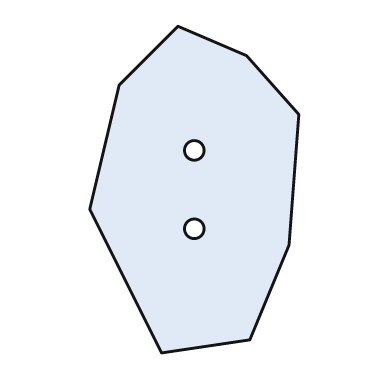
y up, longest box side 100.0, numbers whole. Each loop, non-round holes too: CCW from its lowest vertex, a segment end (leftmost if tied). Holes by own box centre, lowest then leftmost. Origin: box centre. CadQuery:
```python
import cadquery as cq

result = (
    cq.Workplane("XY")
    .moveTo(-10.0, -50.0)
    .lineTo(17.0, -46.0)
    .lineTo(29.0, -17.0)
    .lineTo(32.0, 23.0)
    .lineTo(16.0, 41.0)
    .lineTo(-5.0, 50.0)
    .lineTo(-23.0, 32.0)
    .lineTo(-32.0, -6.0)
    .close()
    .moveTo(0.0, -12.0)
    .circle(3.0)
    .moveTo(0.0, 12.0)
    .circle(3.0)
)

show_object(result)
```